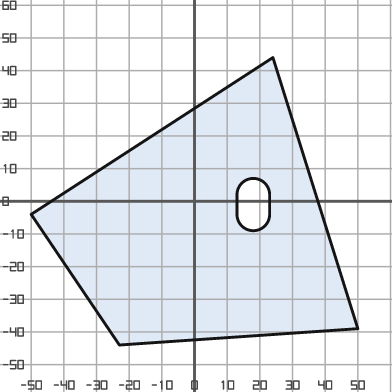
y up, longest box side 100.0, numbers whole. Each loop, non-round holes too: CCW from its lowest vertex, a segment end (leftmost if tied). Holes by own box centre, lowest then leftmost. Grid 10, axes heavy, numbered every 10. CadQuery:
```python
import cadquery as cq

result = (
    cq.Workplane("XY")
    .moveTo(-23.0, -44.0)
    .lineTo(50.0, -39.0)
    .lineTo(24.0, 44.0)
    .lineTo(-50.0, -4.0)
    .close()
    .moveTo(13.0, -4.0)
    .threePointArc((18.0, -9.0), (23.0, -4.0))
    .lineTo(23.0, 2.0)
    .threePointArc((18.0, 7.0), (13.0, 2.0))
    .close()
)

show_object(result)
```